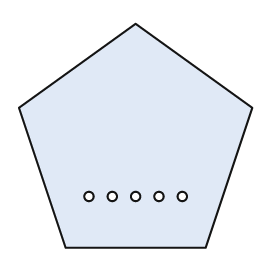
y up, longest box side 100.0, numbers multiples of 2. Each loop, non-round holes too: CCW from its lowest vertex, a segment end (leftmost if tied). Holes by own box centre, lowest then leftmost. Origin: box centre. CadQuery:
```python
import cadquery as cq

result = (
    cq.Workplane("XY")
    .moveTo(-30.0, -48.0)
    .lineTo(30.0, -48.0)
    .lineTo(50.0, 12.0)
    .lineTo(0.0, 48.0)
    .lineTo(-50.0, 12.0)
    .close()
    .moveTo(-20.0, -26.0)
    .circle(2.0)
    .moveTo(-10.0, -26.0)
    .circle(2.0)
    .moveTo(0.0, -26.0)
    .circle(2.0)
    .moveTo(10.0, -26.0)
    .circle(2.0)
    .moveTo(20.0, -26.0)
    .circle(2.0)
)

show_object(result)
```